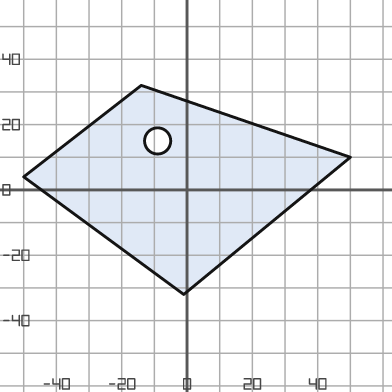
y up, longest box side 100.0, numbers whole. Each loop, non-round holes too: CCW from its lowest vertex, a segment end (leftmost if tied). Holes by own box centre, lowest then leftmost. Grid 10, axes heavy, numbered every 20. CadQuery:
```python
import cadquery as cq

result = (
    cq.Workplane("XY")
    .moveTo(-1.0, -32.0)
    .lineTo(50.0, 10.0)
    .lineTo(-14.0, 32.0)
    .lineTo(-50.0, 4.0)
    .close()
    .moveTo(-9.0, 15.0)
    .circle(4.0)
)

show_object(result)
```